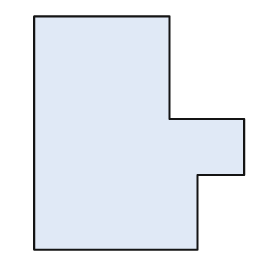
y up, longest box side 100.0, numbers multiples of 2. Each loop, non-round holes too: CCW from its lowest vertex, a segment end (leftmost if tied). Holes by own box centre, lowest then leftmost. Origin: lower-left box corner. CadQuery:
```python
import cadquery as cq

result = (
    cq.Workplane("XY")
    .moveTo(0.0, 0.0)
    .lineTo(70.0, 0.0)
    .lineTo(70.0, 32.0)
    .lineTo(90.0, 32.0)
    .lineTo(90.0, 56.0)
    .lineTo(58.0, 56.0)
    .lineTo(58.0, 100.0)
    .lineTo(0.0, 100.0)
    .close()
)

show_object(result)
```